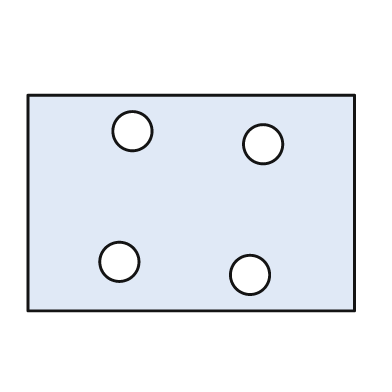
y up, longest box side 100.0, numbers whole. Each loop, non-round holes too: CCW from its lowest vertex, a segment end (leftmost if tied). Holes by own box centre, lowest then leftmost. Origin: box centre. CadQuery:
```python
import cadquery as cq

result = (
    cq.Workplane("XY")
    .moveTo(-50.0, -33.0)
    .lineTo(50.0, -33.0)
    .lineTo(50.0, 33.0)
    .lineTo(-50.0, 33.0)
    .close()
    .moveTo(18.0, -22.0)
    .circle(6.0)
    .moveTo(-22.0, -18.0)
    .circle(6.0)
    .moveTo(22.0, 18.0)
    .circle(6.0)
    .moveTo(-18.0, 22.0)
    .circle(6.0)
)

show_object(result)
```